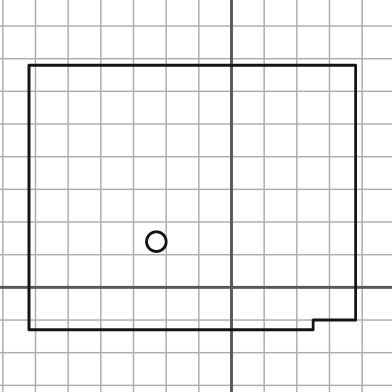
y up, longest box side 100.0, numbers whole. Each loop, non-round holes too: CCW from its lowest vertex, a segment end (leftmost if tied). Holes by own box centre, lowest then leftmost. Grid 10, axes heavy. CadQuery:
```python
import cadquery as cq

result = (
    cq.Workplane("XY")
    .moveTo(-62.0, -13.0)
    .lineTo(25.0, -13.0)
    .lineTo(25.0, -10.0)
    .lineTo(38.0, -10.0)
    .lineTo(38.0, 68.0)
    .lineTo(-62.0, 68.0)
    .close()
    .moveTo(-23.0, 14.0)
    .circle(3.0)
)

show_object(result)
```